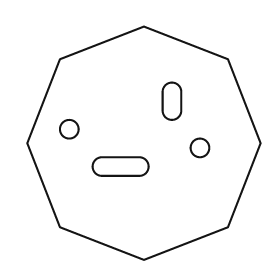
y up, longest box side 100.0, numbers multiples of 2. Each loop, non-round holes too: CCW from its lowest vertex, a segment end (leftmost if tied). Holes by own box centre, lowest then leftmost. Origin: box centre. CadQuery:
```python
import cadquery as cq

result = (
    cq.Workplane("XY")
    .moveTo(0.0, -50.0)
    .lineTo(36.0, -36.0)
    .lineTo(50.0, 0.0)
    .lineTo(36.0, 36.0)
    .lineTo(0.0, 50.0)
    .lineTo(-36.0, 36.0)
    .lineTo(-50.0, 0.0)
    .lineTo(-36.0, -36.0)
    .close()
    .moveTo(-18.0, -14.0)
    .lineTo(-2.0, -14.0)
    .threePointArc((2.0, -10.0), (-2.0, -6.0))
    .lineTo(-18.0, -6.0)
    .threePointArc((-22.0, -10.0), (-18.0, -14.0))
    .close()
    .moveTo(24.0, -2.0)
    .circle(4.0)
    .moveTo(-32.0, 6.0)
    .circle(4.0)
    .moveTo(8.0, 14.0)
    .threePointArc((12.0, 10.0), (16.0, 14.0))
    .lineTo(16.0, 22.0)
    .threePointArc((12.0, 26.0), (8.0, 22.0))
    .close()
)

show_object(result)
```